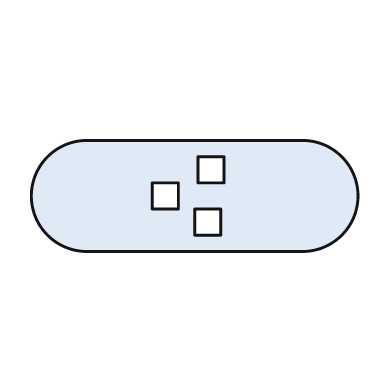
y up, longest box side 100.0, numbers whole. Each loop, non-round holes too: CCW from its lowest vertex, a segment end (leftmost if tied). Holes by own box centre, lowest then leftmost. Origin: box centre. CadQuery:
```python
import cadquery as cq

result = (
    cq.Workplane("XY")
    .moveTo(-33.0, -17.0)
    .lineTo(33.0, -17.0)
    .threePointArc((50.0, 0.0), (33.0, 17.0))
    .lineTo(-33.0, 17.0)
    .threePointArc((-50.0, 0.0), (-33.0, -17.0))
    .close()
    .moveTo(0.0, -12.0)
    .lineTo(8.0, -12.0)
    .lineTo(8.0, -4.0)
    .lineTo(0.0, -4.0)
    .close()
    .moveTo(-13.0, -4.0)
    .lineTo(-5.0, -4.0)
    .lineTo(-5.0, 4.0)
    .lineTo(-13.0, 4.0)
    .close()
    .moveTo(1.0, 4.0)
    .lineTo(9.0, 4.0)
    .lineTo(9.0, 12.0)
    .lineTo(1.0, 12.0)
    .close()
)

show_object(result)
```